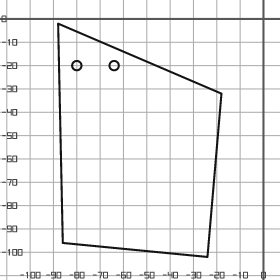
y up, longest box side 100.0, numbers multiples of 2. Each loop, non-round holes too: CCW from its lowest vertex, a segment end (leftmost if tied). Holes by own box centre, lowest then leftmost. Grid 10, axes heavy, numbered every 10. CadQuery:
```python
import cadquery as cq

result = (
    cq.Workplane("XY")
    .moveTo(-24.0, -102.0)
    .lineTo(-18.0, -32.0)
    .lineTo(-88.0, -2.0)
    .lineTo(-86.0, -96.0)
    .close()
    .moveTo(-80.0, -20.0)
    .circle(2.0)
    .moveTo(-64.0, -20.0)
    .circle(2.0)
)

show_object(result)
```